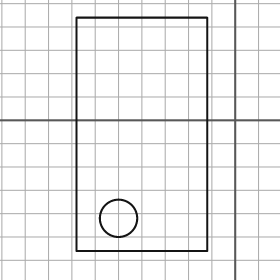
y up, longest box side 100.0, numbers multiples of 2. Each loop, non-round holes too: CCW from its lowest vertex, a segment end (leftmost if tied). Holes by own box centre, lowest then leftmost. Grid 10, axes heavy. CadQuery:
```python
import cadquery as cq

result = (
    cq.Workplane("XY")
    .moveTo(-68.0, -56.0)
    .lineTo(-12.0, -56.0)
    .lineTo(-12.0, 44.0)
    .lineTo(-68.0, 44.0)
    .close()
    .moveTo(-50.0, -42.0)
    .circle(8.0)
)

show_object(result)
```